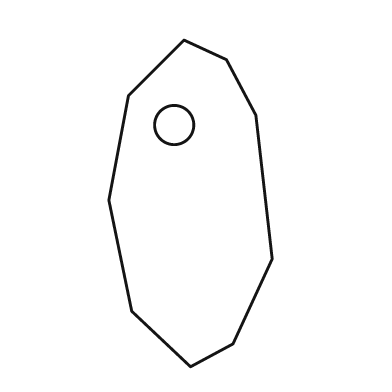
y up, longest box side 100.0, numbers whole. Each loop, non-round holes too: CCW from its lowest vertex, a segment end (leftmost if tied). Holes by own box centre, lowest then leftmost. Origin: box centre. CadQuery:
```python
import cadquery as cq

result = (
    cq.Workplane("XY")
    .moveTo(0.0, -50.0)
    .lineTo(13.0, -43.0)
    .lineTo(25.0, -17.0)
    .lineTo(20.0, 27.0)
    .lineTo(11.0, 44.0)
    .lineTo(-2.0, 50.0)
    .lineTo(-19.0, 33.0)
    .lineTo(-25.0, 1.0)
    .lineTo(-18.0, -33.0)
    .close()
    .moveTo(-5.0, 24.0)
    .circle(6.0)
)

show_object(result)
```